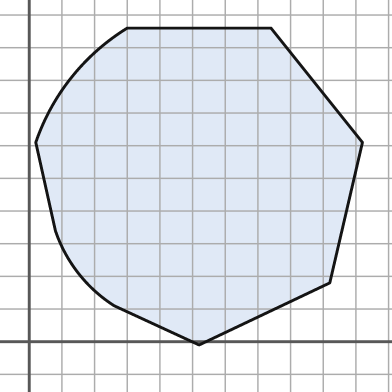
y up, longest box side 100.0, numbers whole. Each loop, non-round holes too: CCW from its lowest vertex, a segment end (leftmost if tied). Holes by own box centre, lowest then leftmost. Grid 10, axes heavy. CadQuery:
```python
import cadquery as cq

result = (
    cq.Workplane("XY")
    .moveTo(52.0, -1.0)
    .lineTo(92.0, 18.0)
    .lineTo(102.0, 61.0)
    .lineTo(74.0, 96.0)
    .lineTo(30.0, 96.0)
    .threePointArc((13.0, 81.0), (2.0, 61.0))
    .lineTo(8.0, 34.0)
    .threePointArc((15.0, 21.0), (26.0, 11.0))
    .close()
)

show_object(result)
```